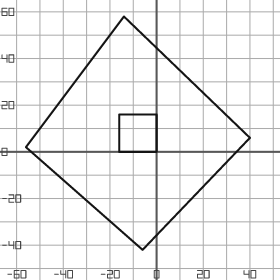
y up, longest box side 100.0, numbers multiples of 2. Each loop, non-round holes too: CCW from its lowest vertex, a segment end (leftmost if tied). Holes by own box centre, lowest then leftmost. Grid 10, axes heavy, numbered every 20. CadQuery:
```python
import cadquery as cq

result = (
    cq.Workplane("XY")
    .moveTo(-6.0, -42.0)
    .lineTo(40.0, 6.0)
    .lineTo(-14.0, 58.0)
    .lineTo(-56.0, 2.0)
    .close()
    .moveTo(-16.0, 0.0)
    .lineTo(0.0, 0.0)
    .lineTo(0.0, 16.0)
    .lineTo(-16.0, 16.0)
    .close()
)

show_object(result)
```